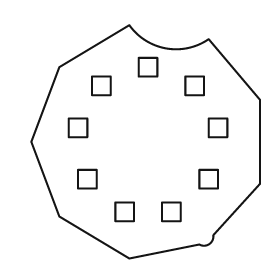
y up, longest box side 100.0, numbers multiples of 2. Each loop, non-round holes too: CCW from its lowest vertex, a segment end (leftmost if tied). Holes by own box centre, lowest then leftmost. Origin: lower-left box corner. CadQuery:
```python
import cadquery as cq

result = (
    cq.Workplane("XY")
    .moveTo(42.0, 0.0)
    .lineTo(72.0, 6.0)
    .threePointArc((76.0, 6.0), (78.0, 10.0))
    .lineTo(98.0, 32.0)
    .lineTo(98.0, 68.0)
    .lineTo(76.0, 94.0)
    .threePointArc((58.0, 90.0), (42.0, 100.0))
    .lineTo(12.0, 82.0)
    .lineTo(0.0, 50.0)
    .lineTo(12.0, 18.0)
    .close()
    .moveTo(36.0, 16.0)
    .lineTo(44.0, 16.0)
    .lineTo(44.0, 24.0)
    .lineTo(36.0, 24.0)
    .close()
    .moveTo(56.0, 16.0)
    .lineTo(64.0, 16.0)
    .lineTo(64.0, 24.0)
    .lineTo(56.0, 24.0)
    .close()
    .moveTo(20.0, 30.0)
    .lineTo(28.0, 30.0)
    .lineTo(28.0, 38.0)
    .lineTo(20.0, 38.0)
    .close()
    .moveTo(72.0, 30.0)
    .lineTo(80.0, 30.0)
    .lineTo(80.0, 38.0)
    .lineTo(72.0, 38.0)
    .close()
    .moveTo(16.0, 52.0)
    .lineTo(24.0, 52.0)
    .lineTo(24.0, 60.0)
    .lineTo(16.0, 60.0)
    .close()
    .moveTo(76.0, 52.0)
    .lineTo(84.0, 52.0)
    .lineTo(84.0, 60.0)
    .lineTo(76.0, 60.0)
    .close()
    .moveTo(26.0, 70.0)
    .lineTo(34.0, 70.0)
    .lineTo(34.0, 78.0)
    .lineTo(26.0, 78.0)
    .close()
    .moveTo(66.0, 70.0)
    .lineTo(74.0, 70.0)
    .lineTo(74.0, 78.0)
    .lineTo(66.0, 78.0)
    .close()
    .moveTo(46.0, 78.0)
    .lineTo(54.0, 78.0)
    .lineTo(54.0, 86.0)
    .lineTo(46.0, 86.0)
    .close()
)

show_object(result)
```